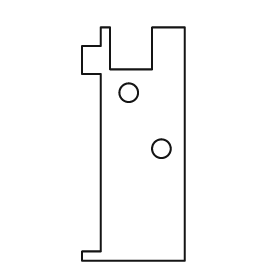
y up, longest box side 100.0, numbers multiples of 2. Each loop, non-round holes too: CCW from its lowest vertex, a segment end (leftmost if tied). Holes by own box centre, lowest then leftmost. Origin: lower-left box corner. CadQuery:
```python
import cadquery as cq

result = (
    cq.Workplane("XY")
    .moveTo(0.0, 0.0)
    .lineTo(44.0, 0.0)
    .lineTo(44.0, 100.0)
    .lineTo(30.0, 100.0)
    .lineTo(30.0, 82.0)
    .lineTo(12.0, 82.0)
    .lineTo(12.0, 100.0)
    .lineTo(8.0, 100.0)
    .lineTo(8.0, 92.0)
    .lineTo(0.0, 92.0)
    .lineTo(0.0, 80.0)
    .lineTo(8.0, 80.0)
    .lineTo(8.0, 4.0)
    .lineTo(0.0, 4.0)
    .close()
    .moveTo(34.0, 48.0)
    .circle(4.0)
    .moveTo(20.0, 72.0)
    .circle(4.0)
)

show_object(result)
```